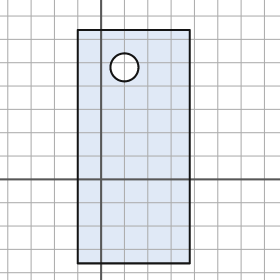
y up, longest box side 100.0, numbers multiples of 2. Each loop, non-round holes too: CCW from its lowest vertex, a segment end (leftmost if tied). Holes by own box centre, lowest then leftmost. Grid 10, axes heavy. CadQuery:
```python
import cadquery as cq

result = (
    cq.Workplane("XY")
    .moveTo(-10.0, -36.0)
    .lineTo(38.0, -36.0)
    .lineTo(38.0, 64.0)
    .lineTo(-10.0, 64.0)
    .close()
    .moveTo(10.0, 48.0)
    .circle(6.0)
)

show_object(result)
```